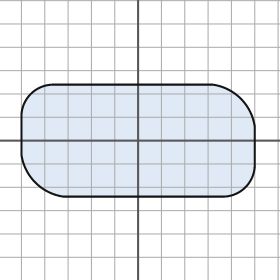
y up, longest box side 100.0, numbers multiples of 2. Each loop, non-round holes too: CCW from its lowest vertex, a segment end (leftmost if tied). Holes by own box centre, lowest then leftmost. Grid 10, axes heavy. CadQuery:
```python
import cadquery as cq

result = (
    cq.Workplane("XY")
    .moveTo(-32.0, -24.0)
    .lineTo(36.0, -24.0)
    .threePointArc((46.0, -20.0), (50.0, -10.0))
    .lineTo(50.0, 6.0)
    .threePointArc((44.0, 18.0), (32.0, 24.0))
    .lineTo(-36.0, 24.0)
    .threePointArc((-46.0, 20.0), (-50.0, 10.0))
    .lineTo(-50.0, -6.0)
    .threePointArc((-44.0, -18.0), (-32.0, -24.0))
    .close()
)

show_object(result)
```